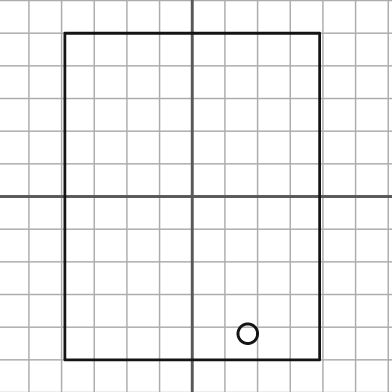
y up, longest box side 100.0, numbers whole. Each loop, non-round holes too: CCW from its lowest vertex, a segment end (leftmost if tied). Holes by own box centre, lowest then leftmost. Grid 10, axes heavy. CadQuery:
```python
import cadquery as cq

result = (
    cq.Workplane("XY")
    .moveTo(-39.0, -50.0)
    .lineTo(39.0, -50.0)
    .lineTo(39.0, 50.0)
    .lineTo(-39.0, 50.0)
    .close()
    .moveTo(17.0, -42.0)
    .circle(3.0)
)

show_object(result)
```